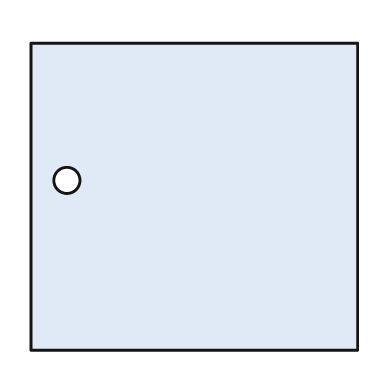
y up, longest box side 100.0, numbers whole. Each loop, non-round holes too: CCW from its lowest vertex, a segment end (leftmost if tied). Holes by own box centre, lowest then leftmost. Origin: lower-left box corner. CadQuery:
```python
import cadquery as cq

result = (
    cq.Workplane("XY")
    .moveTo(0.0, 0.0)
    .lineTo(100.0, 0.0)
    .lineTo(100.0, 94.0)
    .lineTo(0.0, 94.0)
    .close()
    .moveTo(11.0, 52.0)
    .circle(4.0)
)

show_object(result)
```